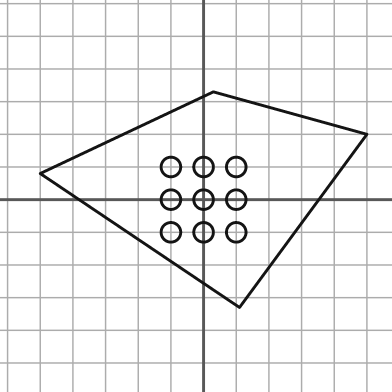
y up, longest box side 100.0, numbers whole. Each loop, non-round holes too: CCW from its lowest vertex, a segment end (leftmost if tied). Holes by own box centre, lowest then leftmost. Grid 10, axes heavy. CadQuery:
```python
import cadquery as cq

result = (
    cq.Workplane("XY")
    .moveTo(11.0, -33.0)
    .lineTo(50.0, 20.0)
    .lineTo(3.0, 33.0)
    .lineTo(-50.0, 8.0)
    .close()
    .moveTo(-10.0, -10.0)
    .circle(3.0)
    .moveTo(0.0, -10.0)
    .circle(3.0)
    .moveTo(10.0, -10.0)
    .circle(3.0)
    .moveTo(-10.0, 0.0)
    .circle(3.0)
    .moveTo(0.0, 0.0)
    .circle(3.0)
    .moveTo(10.0, 0.0)
    .circle(3.0)
    .moveTo(-10.0, 10.0)
    .circle(3.0)
    .moveTo(0.0, 10.0)
    .circle(3.0)
    .moveTo(10.0, 10.0)
    .circle(3.0)
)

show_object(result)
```